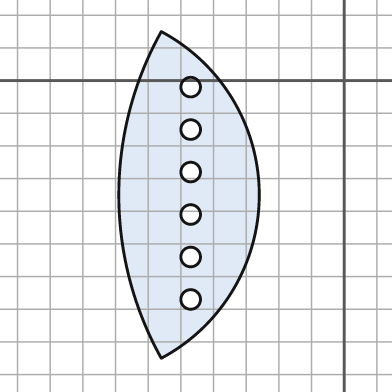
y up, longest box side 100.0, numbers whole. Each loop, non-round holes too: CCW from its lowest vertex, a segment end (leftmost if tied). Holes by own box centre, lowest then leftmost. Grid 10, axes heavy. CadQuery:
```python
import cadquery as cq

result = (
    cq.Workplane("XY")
    .moveTo(-56.0, -85.0)
    .threePointArc((-26.0, -35.0), (-56.0, 15.0))
    .threePointArc((-69.0, -35.0), (-56.0, -85.0))
    .close()
    .moveTo(-47.0, -67.0)
    .circle(3.0)
    .moveTo(-47.0, -54.0)
    .circle(3.0)
    .moveTo(-47.0, -41.0)
    .circle(3.0)
    .moveTo(-47.0, -28.0)
    .circle(3.0)
    .moveTo(-47.0, -15.0)
    .circle(3.0)
    .moveTo(-47.0, -2.0)
    .circle(3.0)
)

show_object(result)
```